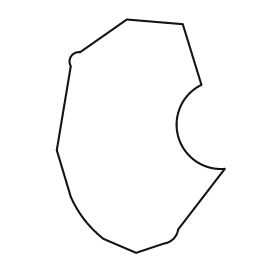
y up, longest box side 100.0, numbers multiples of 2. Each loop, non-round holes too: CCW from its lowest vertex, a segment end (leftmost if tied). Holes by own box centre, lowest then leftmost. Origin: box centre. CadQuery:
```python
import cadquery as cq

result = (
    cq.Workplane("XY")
    .moveTo(-2.0, -50.0)
    .lineTo(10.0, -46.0)
    .threePointArc((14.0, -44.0), (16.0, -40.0))
    .lineTo(36.0, -14.0)
    .threePointArc((16.0, 0.0), (26.0, 22.0))
    .lineTo(18.0, 48.0)
    .lineTo(-6.0, 50.0)
    .lineTo(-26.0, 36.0)
    .threePointArc((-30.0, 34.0), (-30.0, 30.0))
    .lineTo(-36.0, -6.0)
    .lineTo(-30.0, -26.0)
    .threePointArc((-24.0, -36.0), (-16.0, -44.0))
    .close()
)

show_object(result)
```